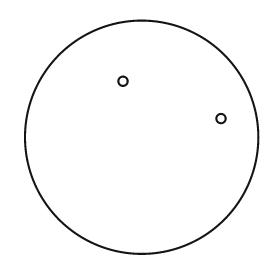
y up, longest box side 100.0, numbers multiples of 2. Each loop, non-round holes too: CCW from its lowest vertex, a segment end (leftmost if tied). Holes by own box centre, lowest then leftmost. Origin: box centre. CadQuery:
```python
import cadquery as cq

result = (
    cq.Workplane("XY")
    .moveTo(0.0, 0.0)
    .circle(50.0)
    .moveTo(34.0, 8.0)
    .circle(2.0)
    .moveTo(-8.0, 24.0)
    .circle(2.0)
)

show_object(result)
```